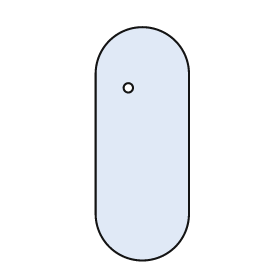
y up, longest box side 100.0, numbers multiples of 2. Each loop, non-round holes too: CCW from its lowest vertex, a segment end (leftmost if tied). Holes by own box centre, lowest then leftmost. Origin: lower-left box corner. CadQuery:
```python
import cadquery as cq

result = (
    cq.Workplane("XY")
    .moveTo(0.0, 20.0)
    .threePointArc((20.0, 0.0), (40.0, 20.0))
    .lineTo(40.0, 80.0)
    .threePointArc((20.0, 100.0), (0.0, 80.0))
    .close()
    .moveTo(14.0, 74.0)
    .circle(2.0)
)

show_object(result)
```